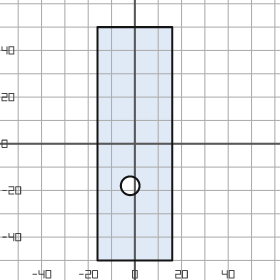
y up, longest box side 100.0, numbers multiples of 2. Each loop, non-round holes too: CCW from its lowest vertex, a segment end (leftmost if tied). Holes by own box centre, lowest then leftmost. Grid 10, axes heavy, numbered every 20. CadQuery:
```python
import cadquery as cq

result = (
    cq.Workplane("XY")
    .moveTo(-16.0, -50.0)
    .lineTo(16.0, -50.0)
    .lineTo(16.0, 50.0)
    .lineTo(-16.0, 50.0)
    .close()
    .moveTo(-2.0, -18.0)
    .circle(4.0)
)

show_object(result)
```